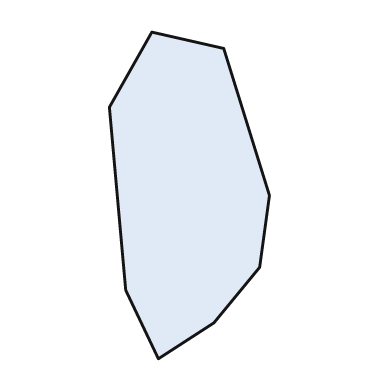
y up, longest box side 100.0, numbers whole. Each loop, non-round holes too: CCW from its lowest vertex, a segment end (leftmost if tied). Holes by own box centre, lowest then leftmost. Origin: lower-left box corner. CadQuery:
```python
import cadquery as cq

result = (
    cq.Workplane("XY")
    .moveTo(15.0, 0.0)
    .lineTo(32.0, 11.0)
    .lineTo(46.0, 28.0)
    .lineTo(49.0, 50.0)
    .lineTo(35.0, 95.0)
    .lineTo(13.0, 100.0)
    .lineTo(0.0, 77.0)
    .lineTo(5.0, 21.0)
    .close()
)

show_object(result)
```